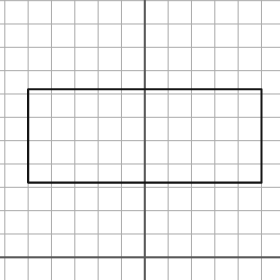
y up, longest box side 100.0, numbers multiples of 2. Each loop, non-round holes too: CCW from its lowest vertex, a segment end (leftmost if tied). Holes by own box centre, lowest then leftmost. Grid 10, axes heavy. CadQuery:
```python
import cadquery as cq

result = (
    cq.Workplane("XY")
    .moveTo(-50.0, 32.0)
    .lineTo(50.0, 32.0)
    .lineTo(50.0, 72.0)
    .lineTo(-50.0, 72.0)
    .close()
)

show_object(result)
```